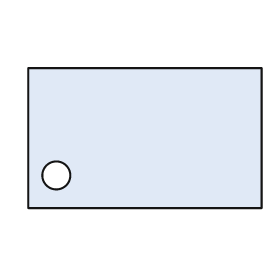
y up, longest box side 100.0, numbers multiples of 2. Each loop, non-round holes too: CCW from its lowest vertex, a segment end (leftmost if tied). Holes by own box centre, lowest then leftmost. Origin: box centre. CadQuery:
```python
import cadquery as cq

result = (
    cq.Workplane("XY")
    .moveTo(-50.0, -30.0)
    .lineTo(50.0, -30.0)
    .lineTo(50.0, 30.0)
    .lineTo(-50.0, 30.0)
    .close()
    .moveTo(-38.0, -16.0)
    .circle(6.0)
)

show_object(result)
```